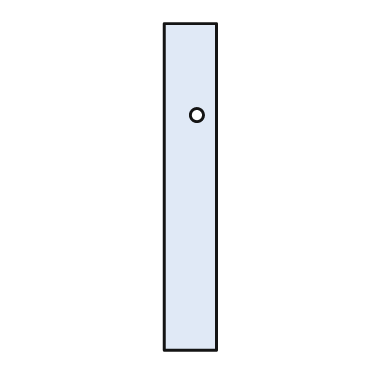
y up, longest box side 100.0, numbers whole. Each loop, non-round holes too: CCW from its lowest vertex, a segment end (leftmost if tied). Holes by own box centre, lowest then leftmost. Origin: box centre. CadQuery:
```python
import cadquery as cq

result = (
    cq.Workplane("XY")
    .moveTo(-8.0, -50.0)
    .lineTo(8.0, -50.0)
    .lineTo(8.0, 50.0)
    .lineTo(-8.0, 50.0)
    .close()
    .moveTo(2.0, 22.0)
    .circle(2.0)
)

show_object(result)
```